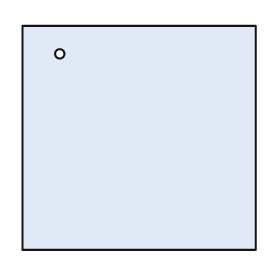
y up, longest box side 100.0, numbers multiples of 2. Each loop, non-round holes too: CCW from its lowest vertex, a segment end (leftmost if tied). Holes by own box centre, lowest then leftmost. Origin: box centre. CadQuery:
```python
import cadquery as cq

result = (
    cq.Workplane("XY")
    .moveTo(-50.0, -48.0)
    .lineTo(50.0, -48.0)
    .lineTo(50.0, 48.0)
    .lineTo(-50.0, 48.0)
    .close()
    .moveTo(-34.0, 36.0)
    .circle(2.0)
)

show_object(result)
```